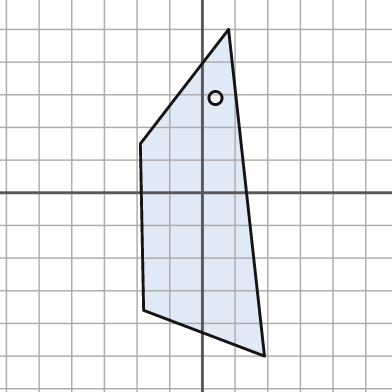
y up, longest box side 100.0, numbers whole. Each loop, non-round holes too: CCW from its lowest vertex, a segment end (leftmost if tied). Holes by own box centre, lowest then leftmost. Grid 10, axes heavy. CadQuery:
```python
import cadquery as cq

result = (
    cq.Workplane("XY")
    .moveTo(19.0, -50.0)
    .lineTo(8.0, 50.0)
    .lineTo(-19.0, 15.0)
    .lineTo(-18.0, -36.0)
    .close()
    .moveTo(4.0, 29.0)
    .circle(2.0)
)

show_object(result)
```